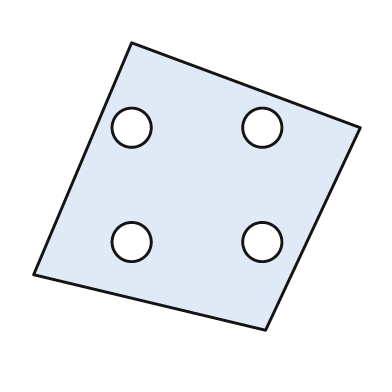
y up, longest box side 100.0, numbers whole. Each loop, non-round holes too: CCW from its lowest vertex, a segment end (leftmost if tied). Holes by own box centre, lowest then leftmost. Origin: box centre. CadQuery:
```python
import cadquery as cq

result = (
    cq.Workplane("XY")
    .moveTo(21.0, -44.0)
    .lineTo(50.0, 18.0)
    .lineTo(-20.0, 44.0)
    .lineTo(-50.0, -27.0)
    .close()
    .moveTo(-20.0, -17.0)
    .circle(6.0)
    .moveTo(20.0, -17.0)
    .circle(6.0)
    .moveTo(-20.0, 18.0)
    .circle(6.0)
    .moveTo(20.0, 18.0)
    .circle(6.0)
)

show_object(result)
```